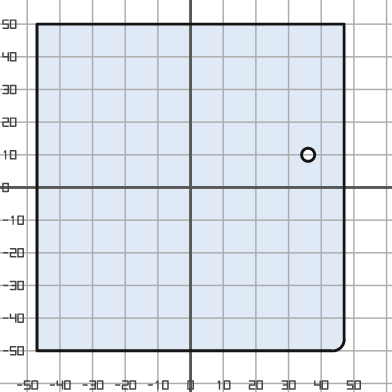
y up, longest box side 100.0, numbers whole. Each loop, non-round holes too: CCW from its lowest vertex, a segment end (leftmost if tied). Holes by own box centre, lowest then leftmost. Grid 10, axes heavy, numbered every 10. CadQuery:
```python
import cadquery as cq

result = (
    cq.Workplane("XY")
    .moveTo(-47.0, -50.0)
    .lineTo(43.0, -50.0)
    .threePointArc((46.0, -49.0), (47.0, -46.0))
    .lineTo(47.0, 50.0)
    .lineTo(-47.0, 50.0)
    .close()
    .moveTo(36.0, 10.0)
    .circle(2.0)
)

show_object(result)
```